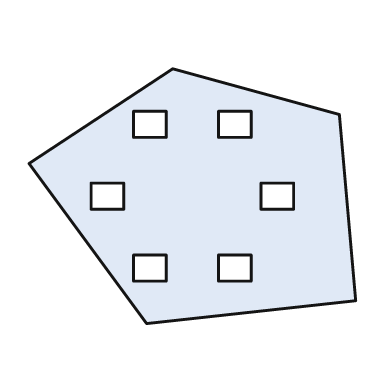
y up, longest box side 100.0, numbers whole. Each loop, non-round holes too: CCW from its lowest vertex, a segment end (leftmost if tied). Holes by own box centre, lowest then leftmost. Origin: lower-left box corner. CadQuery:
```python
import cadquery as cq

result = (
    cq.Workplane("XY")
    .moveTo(36.0, 0.0)
    .lineTo(100.0, 7.0)
    .lineTo(95.0, 64.0)
    .lineTo(44.0, 78.0)
    .lineTo(0.0, 49.0)
    .close()
    .moveTo(32.0, 13.0)
    .lineTo(42.0, 13.0)
    .lineTo(42.0, 21.0)
    .lineTo(32.0, 21.0)
    .close()
    .moveTo(58.0, 13.0)
    .lineTo(68.0, 13.0)
    .lineTo(68.0, 21.0)
    .lineTo(58.0, 21.0)
    .close()
    .moveTo(19.0, 35.0)
    .lineTo(29.0, 35.0)
    .lineTo(29.0, 43.0)
    .lineTo(19.0, 43.0)
    .close()
    .moveTo(71.0, 35.0)
    .lineTo(81.0, 35.0)
    .lineTo(81.0, 43.0)
    .lineTo(71.0, 43.0)
    .close()
    .moveTo(32.0, 57.0)
    .lineTo(42.0, 57.0)
    .lineTo(42.0, 65.0)
    .lineTo(32.0, 65.0)
    .close()
    .moveTo(58.0, 57.0)
    .lineTo(68.0, 57.0)
    .lineTo(68.0, 65.0)
    .lineTo(58.0, 65.0)
    .close()
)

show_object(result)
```